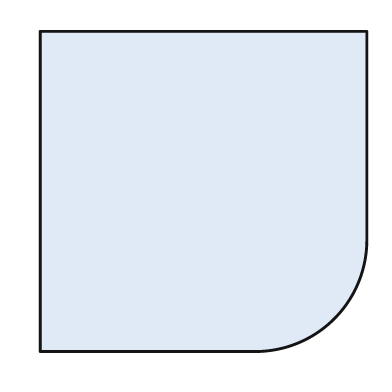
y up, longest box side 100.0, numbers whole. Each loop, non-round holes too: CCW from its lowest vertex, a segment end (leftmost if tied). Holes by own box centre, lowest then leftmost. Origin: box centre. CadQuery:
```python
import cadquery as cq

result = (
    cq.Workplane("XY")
    .moveTo(-50.0, -49.0)
    .lineTo(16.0, -49.0)
    .threePointArc((40.0, -39.0), (50.0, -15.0))
    .lineTo(50.0, 49.0)
    .lineTo(-50.0, 49.0)
    .close()
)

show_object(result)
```